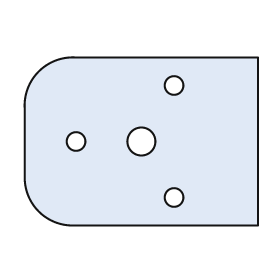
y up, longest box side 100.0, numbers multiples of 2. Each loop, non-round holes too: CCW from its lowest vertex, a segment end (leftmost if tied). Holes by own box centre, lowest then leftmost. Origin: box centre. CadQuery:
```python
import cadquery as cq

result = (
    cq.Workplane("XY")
    .moveTo(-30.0, -36.0)
    .lineTo(50.0, -36.0)
    .lineTo(50.0, 36.0)
    .lineTo(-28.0, 36.0)
    .threePointArc((-44.0, 30.0), (-50.0, 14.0))
    .lineTo(-50.0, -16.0)
    .threePointArc((-44.0, -30.0), (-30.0, -36.0))
    .close()
    .moveTo(14.0, -24.0)
    .circle(4.0)
    .moveTo(-28.0, 0.0)
    .circle(4.0)
    .moveTo(0.0, 0.0)
    .circle(6.0)
    .moveTo(14.0, 24.0)
    .circle(4.0)
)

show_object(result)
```